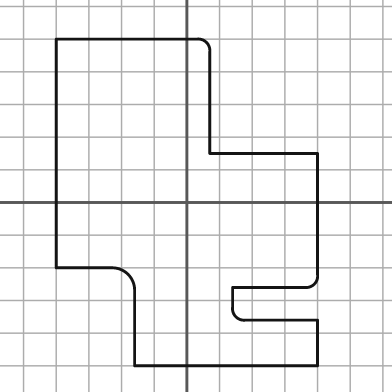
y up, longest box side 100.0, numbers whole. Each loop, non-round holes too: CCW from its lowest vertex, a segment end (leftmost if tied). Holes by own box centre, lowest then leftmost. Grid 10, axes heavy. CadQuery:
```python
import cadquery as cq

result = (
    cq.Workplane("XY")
    .moveTo(-16.0, -50.0)
    .lineTo(40.0, -50.0)
    .lineTo(40.0, -36.0)
    .lineTo(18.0, -36.0)
    .threePointArc((15.0, -35.0), (14.0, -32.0))
    .lineTo(14.0, -26.0)
    .lineTo(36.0, -26.0)
    .threePointArc((39.0, -25.0), (40.0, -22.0))
    .lineTo(40.0, 15.0)
    .lineTo(7.0, 15.0)
    .lineTo(7.0, 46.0)
    .threePointArc((6.0, 49.0), (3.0, 50.0))
    .lineTo(-40.0, 50.0)
    .lineTo(-40.0, -20.0)
    .lineTo(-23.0, -20.0)
    .threePointArc((-18.0, -22.0), (-16.0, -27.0))
    .close()
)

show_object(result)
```